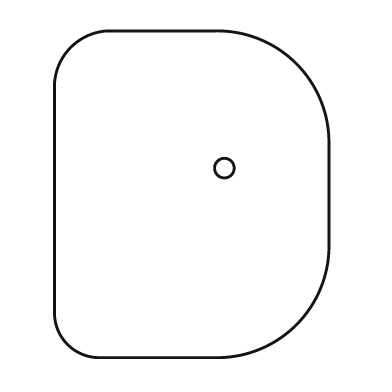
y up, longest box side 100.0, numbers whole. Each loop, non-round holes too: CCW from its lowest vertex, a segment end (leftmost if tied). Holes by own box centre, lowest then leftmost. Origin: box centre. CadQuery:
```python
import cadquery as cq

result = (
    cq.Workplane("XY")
    .moveTo(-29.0, -50.0)
    .lineTo(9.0, -50.0)
    .threePointArc((32.0, -40.0), (42.0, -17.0))
    .lineTo(42.0, 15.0)
    .threePointArc((32.0, 40.0), (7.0, 50.0))
    .lineTo(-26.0, 50.0)
    .threePointArc((-37.0, 45.0), (-42.0, 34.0))
    .lineTo(-42.0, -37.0)
    .threePointArc((-38.0, -46.0), (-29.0, -50.0))
    .close()
    .moveTo(10.0, 8.0)
    .circle(3.0)
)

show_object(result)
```